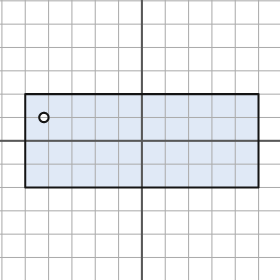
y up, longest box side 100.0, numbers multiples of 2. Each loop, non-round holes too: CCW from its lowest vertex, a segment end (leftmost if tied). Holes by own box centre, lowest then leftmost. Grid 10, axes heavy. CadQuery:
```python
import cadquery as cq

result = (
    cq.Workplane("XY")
    .moveTo(-50.0, -20.0)
    .lineTo(50.0, -20.0)
    .lineTo(50.0, 20.0)
    .lineTo(-50.0, 20.0)
    .close()
    .moveTo(-42.0, 10.0)
    .circle(2.0)
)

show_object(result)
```